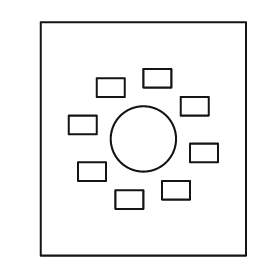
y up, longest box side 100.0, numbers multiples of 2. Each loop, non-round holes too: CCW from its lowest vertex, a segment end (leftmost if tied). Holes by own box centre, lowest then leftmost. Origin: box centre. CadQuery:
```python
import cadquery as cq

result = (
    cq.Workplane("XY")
    .moveTo(-44.0, -50.0)
    .lineTo(44.0, -50.0)
    .lineTo(44.0, 50.0)
    .lineTo(-44.0, 50.0)
    .close()
    .moveTo(-12.0, -30.0)
    .lineTo(0.0, -30.0)
    .lineTo(0.0, -22.0)
    .lineTo(-12.0, -22.0)
    .close()
    .moveTo(8.0, -26.0)
    .lineTo(20.0, -26.0)
    .lineTo(20.0, -18.0)
    .lineTo(8.0, -18.0)
    .close()
    .moveTo(-28.0, -18.0)
    .lineTo(-16.0, -18.0)
    .lineTo(-16.0, -10.0)
    .lineTo(-28.0, -10.0)
    .close()
    .moveTo(20.0, -10.0)
    .lineTo(32.0, -10.0)
    .lineTo(32.0, -2.0)
    .lineTo(20.0, -2.0)
    .close()
    .moveTo(0.0, 0.0)
    .circle(14.0)
    .moveTo(-32.0, 2.0)
    .lineTo(-20.0, 2.0)
    .lineTo(-20.0, 10.0)
    .lineTo(-32.0, 10.0)
    .close()
    .moveTo(16.0, 10.0)
    .lineTo(28.0, 10.0)
    .lineTo(28.0, 18.0)
    .lineTo(16.0, 18.0)
    .close()
    .moveTo(-20.0, 18.0)
    .lineTo(-8.0, 18.0)
    .lineTo(-8.0, 26.0)
    .lineTo(-20.0, 26.0)
    .close()
    .moveTo(0.0, 22.0)
    .lineTo(12.0, 22.0)
    .lineTo(12.0, 30.0)
    .lineTo(0.0, 30.0)
    .close()
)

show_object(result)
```